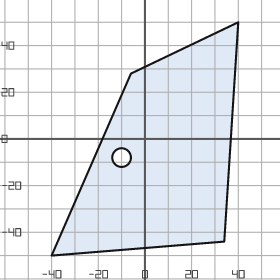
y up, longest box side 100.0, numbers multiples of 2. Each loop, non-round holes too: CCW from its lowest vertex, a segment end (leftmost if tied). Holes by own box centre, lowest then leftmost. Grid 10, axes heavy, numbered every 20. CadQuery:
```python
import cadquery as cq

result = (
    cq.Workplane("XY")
    .moveTo(-40.0, -50.0)
    .lineTo(34.0, -44.0)
    .lineTo(40.0, 50.0)
    .lineTo(-6.0, 28.0)
    .close()
    .moveTo(-10.0, -8.0)
    .circle(4.0)
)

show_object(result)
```